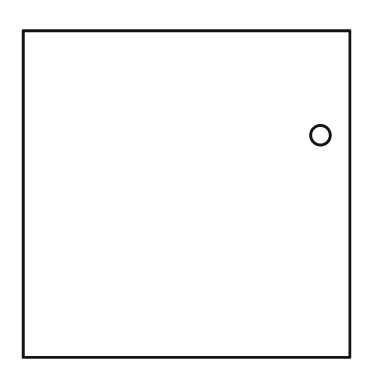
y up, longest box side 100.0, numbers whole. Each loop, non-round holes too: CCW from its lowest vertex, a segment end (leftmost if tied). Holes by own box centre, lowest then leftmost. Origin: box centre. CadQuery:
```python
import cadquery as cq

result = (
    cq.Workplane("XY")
    .moveTo(-50.0, -50.0)
    .lineTo(50.0, -50.0)
    .lineTo(50.0, 50.0)
    .lineTo(-50.0, 50.0)
    .close()
    .moveTo(41.0, 18.0)
    .circle(3.0)
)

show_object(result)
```